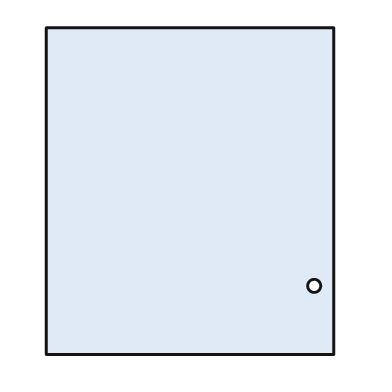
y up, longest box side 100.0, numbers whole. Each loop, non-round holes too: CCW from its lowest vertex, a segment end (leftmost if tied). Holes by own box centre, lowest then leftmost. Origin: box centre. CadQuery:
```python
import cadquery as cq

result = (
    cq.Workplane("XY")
    .moveTo(-44.0, -50.0)
    .lineTo(44.0, -50.0)
    .lineTo(44.0, 50.0)
    .lineTo(-44.0, 50.0)
    .close()
    .moveTo(38.0, -29.0)
    .circle(2.0)
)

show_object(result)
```